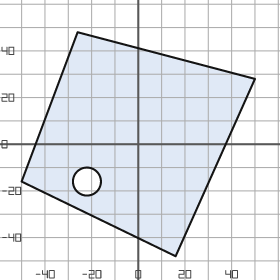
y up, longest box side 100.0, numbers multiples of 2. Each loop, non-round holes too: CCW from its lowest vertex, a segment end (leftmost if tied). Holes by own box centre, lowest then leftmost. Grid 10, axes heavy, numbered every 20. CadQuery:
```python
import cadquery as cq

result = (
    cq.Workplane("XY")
    .moveTo(16.0, -48.0)
    .lineTo(50.0, 28.0)
    .lineTo(-26.0, 48.0)
    .lineTo(-50.0, -16.0)
    .close()
    .moveTo(-22.0, -16.0)
    .circle(6.0)
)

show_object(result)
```